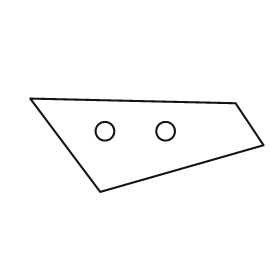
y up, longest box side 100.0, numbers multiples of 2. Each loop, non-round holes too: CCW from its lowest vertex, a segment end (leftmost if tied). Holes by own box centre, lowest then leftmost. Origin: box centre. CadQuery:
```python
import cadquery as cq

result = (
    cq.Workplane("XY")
    .moveTo(-20.0, -20.0)
    .lineTo(50.0, 0.0)
    .lineTo(38.0, 18.0)
    .lineTo(-50.0, 20.0)
    .close()
    .moveTo(-18.0, 6.0)
    .circle(4.0)
    .moveTo(8.0, 6.0)
    .circle(4.0)
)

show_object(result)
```